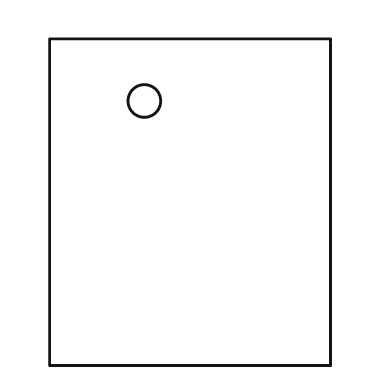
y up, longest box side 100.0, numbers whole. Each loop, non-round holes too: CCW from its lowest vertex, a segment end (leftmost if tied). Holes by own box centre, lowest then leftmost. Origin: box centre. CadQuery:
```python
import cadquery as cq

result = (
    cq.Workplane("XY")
    .moveTo(-43.0, -50.0)
    .lineTo(43.0, -50.0)
    .lineTo(43.0, 50.0)
    .lineTo(-43.0, 50.0)
    .close()
    .moveTo(-14.0, 31.0)
    .circle(5.0)
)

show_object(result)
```